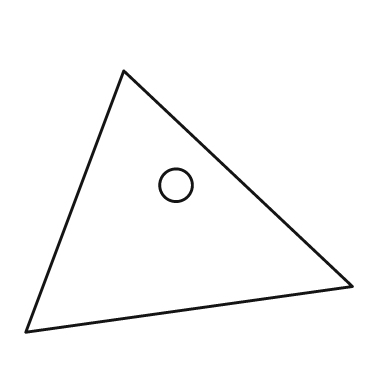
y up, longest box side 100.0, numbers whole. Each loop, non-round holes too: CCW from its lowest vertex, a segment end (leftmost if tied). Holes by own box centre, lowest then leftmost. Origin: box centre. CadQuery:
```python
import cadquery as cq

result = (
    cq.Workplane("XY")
    .moveTo(-50.0, -40.0)
    .lineTo(50.0, -26.0)
    .lineTo(-20.0, 40.0)
    .close()
    .moveTo(-4.0, 5.0)
    .circle(5.0)
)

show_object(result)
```